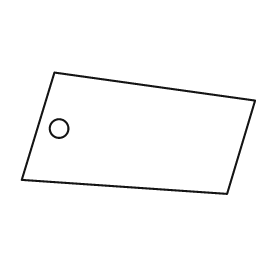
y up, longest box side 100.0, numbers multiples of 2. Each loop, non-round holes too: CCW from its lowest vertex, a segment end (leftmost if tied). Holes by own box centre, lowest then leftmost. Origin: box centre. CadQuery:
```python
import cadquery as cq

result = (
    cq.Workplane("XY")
    .moveTo(38.0, -26.0)
    .lineTo(50.0, 14.0)
    .lineTo(-36.0, 26.0)
    .lineTo(-50.0, -20.0)
    .close()
    .moveTo(-34.0, 2.0)
    .circle(4.0)
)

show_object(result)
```